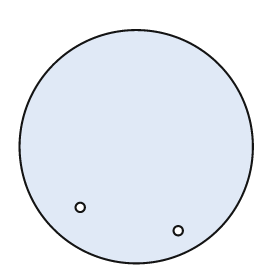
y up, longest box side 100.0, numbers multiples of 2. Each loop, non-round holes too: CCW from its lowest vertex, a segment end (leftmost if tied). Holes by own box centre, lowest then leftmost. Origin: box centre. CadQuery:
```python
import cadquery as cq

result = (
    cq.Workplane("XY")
    .moveTo(0.0, 0.0)
    .circle(50.0)
    .moveTo(18.0, -36.0)
    .circle(2.0)
    .moveTo(-24.0, -26.0)
    .circle(2.0)
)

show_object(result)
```